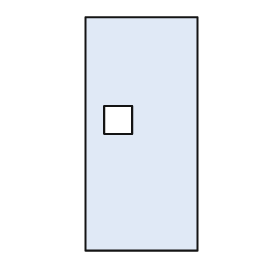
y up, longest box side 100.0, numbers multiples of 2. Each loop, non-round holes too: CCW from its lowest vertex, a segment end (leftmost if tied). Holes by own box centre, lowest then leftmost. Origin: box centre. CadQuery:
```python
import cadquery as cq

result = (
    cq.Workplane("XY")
    .moveTo(-24.0, -50.0)
    .lineTo(24.0, -50.0)
    .lineTo(24.0, 50.0)
    .lineTo(-24.0, 50.0)
    .close()
    .moveTo(-16.0, 0.0)
    .lineTo(-4.0, 0.0)
    .lineTo(-4.0, 12.0)
    .lineTo(-16.0, 12.0)
    .close()
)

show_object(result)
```